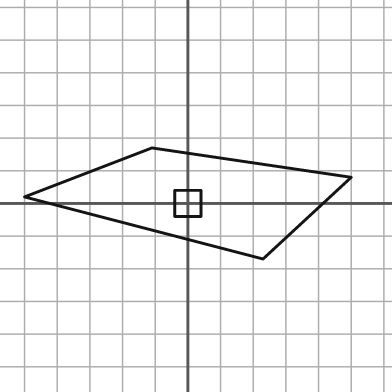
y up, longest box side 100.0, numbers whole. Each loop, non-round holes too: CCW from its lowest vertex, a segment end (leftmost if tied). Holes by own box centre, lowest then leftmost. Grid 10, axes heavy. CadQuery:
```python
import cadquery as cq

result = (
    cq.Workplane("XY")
    .moveTo(23.0, -17.0)
    .lineTo(50.0, 8.0)
    .lineTo(-11.0, 17.0)
    .lineTo(-50.0, 2.0)
    .close()
    .moveTo(-4.0, -4.0)
    .lineTo(4.0, -4.0)
    .lineTo(4.0, 4.0)
    .lineTo(-4.0, 4.0)
    .close()
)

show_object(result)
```